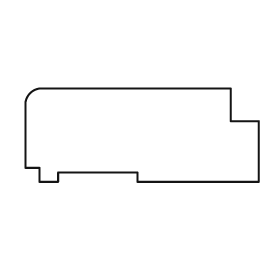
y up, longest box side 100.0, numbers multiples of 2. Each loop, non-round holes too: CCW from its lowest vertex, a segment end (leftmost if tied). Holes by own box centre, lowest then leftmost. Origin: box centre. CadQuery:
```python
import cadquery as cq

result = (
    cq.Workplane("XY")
    .moveTo(-44.0, -20.0)
    .lineTo(-36.0, -20.0)
    .lineTo(-36.0, -16.0)
    .lineTo(-2.0, -16.0)
    .lineTo(-2.0, -20.0)
    .lineTo(50.0, -20.0)
    .lineTo(50.0, 6.0)
    .lineTo(38.0, 6.0)
    .lineTo(38.0, 20.0)
    .lineTo(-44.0, 20.0)
    .threePointArc((-48.0, 18.0), (-50.0, 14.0))
    .lineTo(-50.0, -14.0)
    .lineTo(-44.0, -14.0)
    .close()
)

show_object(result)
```